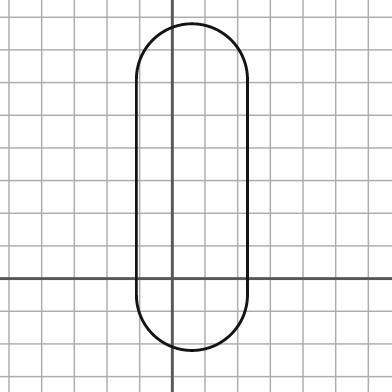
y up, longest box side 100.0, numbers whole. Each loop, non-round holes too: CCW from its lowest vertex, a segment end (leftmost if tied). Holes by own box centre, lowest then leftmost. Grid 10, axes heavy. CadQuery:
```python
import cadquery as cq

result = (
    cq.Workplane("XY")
    .moveTo(-11.0, -5.0)
    .threePointArc((6.0, -22.0), (23.0, -5.0))
    .lineTo(23.0, 61.0)
    .threePointArc((6.0, 78.0), (-11.0, 61.0))
    .close()
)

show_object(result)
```